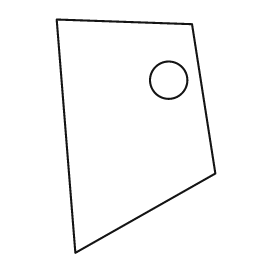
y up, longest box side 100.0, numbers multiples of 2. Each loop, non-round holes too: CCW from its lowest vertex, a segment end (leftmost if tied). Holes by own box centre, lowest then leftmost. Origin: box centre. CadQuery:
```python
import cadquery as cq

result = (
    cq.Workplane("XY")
    .moveTo(-26.0, -50.0)
    .lineTo(34.0, -16.0)
    .lineTo(24.0, 48.0)
    .lineTo(-34.0, 50.0)
    .close()
    .moveTo(14.0, 24.0)
    .circle(8.0)
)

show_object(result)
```